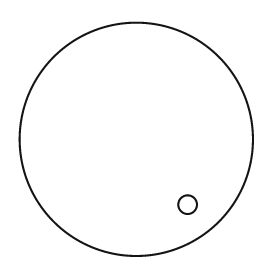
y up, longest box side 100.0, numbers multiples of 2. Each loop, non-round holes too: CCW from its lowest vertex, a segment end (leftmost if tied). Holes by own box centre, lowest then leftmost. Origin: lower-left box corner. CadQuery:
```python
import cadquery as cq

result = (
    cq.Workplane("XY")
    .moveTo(50.0, 50.0)
    .circle(50.0)
    .moveTo(72.0, 22.0)
    .circle(4.0)
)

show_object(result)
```